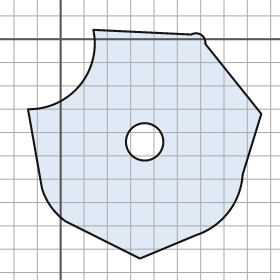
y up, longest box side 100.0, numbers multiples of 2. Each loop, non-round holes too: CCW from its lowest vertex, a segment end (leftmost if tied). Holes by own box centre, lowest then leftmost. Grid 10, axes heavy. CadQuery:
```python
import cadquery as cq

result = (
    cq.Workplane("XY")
    .moveTo(34.0, -94.0)
    .lineTo(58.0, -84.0)
    .threePointArc((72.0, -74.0), (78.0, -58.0))
    .lineTo(86.0, -32.0)
    .lineTo(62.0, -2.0)
    .threePointArc((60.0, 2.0), (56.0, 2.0))
    .lineTo(14.0, 4.0)
    .threePointArc((8.0, -20.0), (-14.0, -30.0))
    .lineTo(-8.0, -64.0)
    .threePointArc((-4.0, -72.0), (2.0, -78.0))
    .close()
    .moveTo(36.0, -44.0)
    .circle(8.0)
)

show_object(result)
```